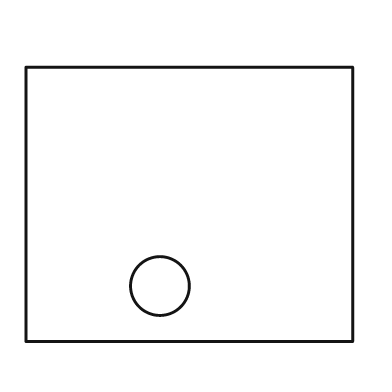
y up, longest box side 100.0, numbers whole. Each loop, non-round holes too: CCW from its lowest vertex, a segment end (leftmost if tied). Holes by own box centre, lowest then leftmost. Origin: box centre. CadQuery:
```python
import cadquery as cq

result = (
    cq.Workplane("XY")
    .moveTo(-50.0, -42.0)
    .lineTo(50.0, -42.0)
    .lineTo(50.0, 42.0)
    .lineTo(-50.0, 42.0)
    .close()
    .moveTo(-9.0, -25.0)
    .circle(9.0)
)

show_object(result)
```